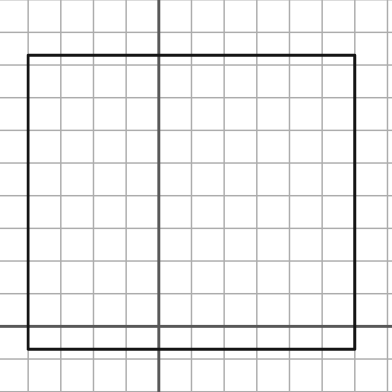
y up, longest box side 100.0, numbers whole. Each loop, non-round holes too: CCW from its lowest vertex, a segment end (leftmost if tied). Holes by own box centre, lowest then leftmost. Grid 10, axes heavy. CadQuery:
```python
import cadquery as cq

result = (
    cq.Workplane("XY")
    .moveTo(-40.0, -7.0)
    .lineTo(60.0, -7.0)
    .lineTo(60.0, 83.0)
    .lineTo(-40.0, 83.0)
    .close()
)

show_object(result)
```